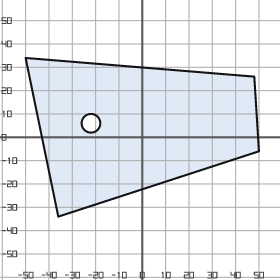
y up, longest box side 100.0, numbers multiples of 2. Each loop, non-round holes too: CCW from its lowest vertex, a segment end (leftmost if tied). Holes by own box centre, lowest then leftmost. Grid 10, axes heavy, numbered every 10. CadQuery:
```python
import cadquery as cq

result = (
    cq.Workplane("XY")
    .moveTo(-36.0, -34.0)
    .lineTo(50.0, -6.0)
    .lineTo(48.0, 26.0)
    .lineTo(-50.0, 34.0)
    .close()
    .moveTo(-22.0, 6.0)
    .circle(4.0)
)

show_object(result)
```